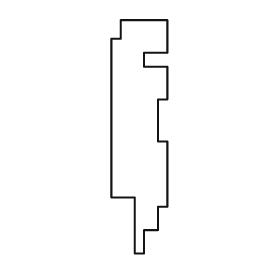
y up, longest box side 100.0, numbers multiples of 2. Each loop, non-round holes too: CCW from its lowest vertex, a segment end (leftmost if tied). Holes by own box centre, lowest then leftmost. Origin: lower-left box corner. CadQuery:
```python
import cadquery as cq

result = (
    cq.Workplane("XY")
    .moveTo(10.0, 0.0)
    .lineTo(14.0, 0.0)
    .lineTo(14.0, 10.0)
    .lineTo(20.0, 10.0)
    .lineTo(20.0, 20.0)
    .lineTo(24.0, 20.0)
    .lineTo(24.0, 48.0)
    .lineTo(20.0, 48.0)
    .lineTo(20.0, 66.0)
    .lineTo(24.0, 66.0)
    .lineTo(24.0, 80.0)
    .lineTo(14.0, 80.0)
    .lineTo(14.0, 86.0)
    .lineTo(24.0, 86.0)
    .lineTo(24.0, 100.0)
    .lineTo(4.0, 100.0)
    .lineTo(4.0, 92.0)
    .lineTo(0.0, 92.0)
    .lineTo(0.0, 24.0)
    .lineTo(10.0, 24.0)
    .close()
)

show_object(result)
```